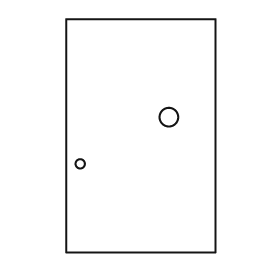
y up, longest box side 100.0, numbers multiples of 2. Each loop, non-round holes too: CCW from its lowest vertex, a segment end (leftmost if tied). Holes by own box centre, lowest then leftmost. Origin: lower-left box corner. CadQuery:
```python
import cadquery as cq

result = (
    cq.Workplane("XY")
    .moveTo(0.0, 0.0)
    .lineTo(64.0, 0.0)
    .lineTo(64.0, 100.0)
    .lineTo(0.0, 100.0)
    .close()
    .moveTo(6.0, 38.0)
    .circle(2.0)
    .moveTo(44.0, 58.0)
    .circle(4.0)
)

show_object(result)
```